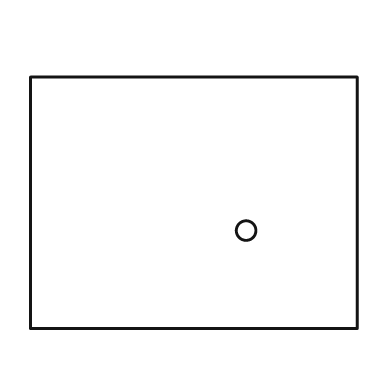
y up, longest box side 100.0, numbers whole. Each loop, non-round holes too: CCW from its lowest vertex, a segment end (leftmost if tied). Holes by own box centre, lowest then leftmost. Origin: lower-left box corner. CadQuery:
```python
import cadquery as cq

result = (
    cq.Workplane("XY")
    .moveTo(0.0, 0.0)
    .lineTo(100.0, 0.0)
    .lineTo(100.0, 77.0)
    .lineTo(0.0, 77.0)
    .close()
    .moveTo(66.0, 30.0)
    .circle(3.0)
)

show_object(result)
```